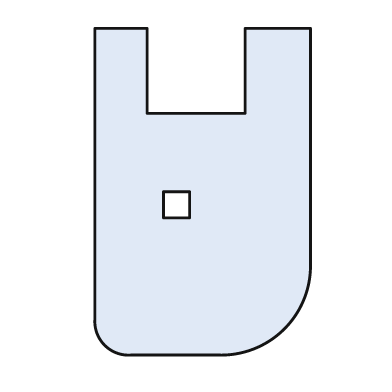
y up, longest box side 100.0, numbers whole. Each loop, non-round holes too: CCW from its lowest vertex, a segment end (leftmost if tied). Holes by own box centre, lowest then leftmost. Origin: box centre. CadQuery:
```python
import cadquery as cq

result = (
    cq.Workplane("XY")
    .moveTo(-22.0, -50.0)
    .lineTo(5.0, -50.0)
    .threePointArc((25.0, -42.0), (33.0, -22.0))
    .lineTo(33.0, 50.0)
    .lineTo(13.0, 50.0)
    .lineTo(13.0, 24.0)
    .lineTo(-17.0, 24.0)
    .lineTo(-17.0, 50.0)
    .lineTo(-33.0, 50.0)
    .lineTo(-33.0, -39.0)
    .threePointArc((-30.0, -47.0), (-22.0, -50.0))
    .close()
    .moveTo(-12.0, -8.0)
    .lineTo(-4.0, -8.0)
    .lineTo(-4.0, 0.0)
    .lineTo(-12.0, 0.0)
    .close()
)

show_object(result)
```